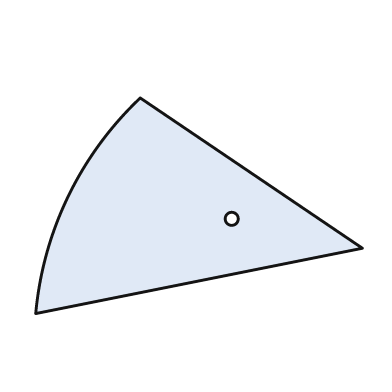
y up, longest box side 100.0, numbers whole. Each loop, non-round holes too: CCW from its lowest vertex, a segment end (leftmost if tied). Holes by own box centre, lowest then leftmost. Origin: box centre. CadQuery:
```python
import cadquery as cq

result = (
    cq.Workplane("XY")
    .moveTo(-50.0, -33.0)
    .lineTo(50.0, -13.0)
    .lineTo(-18.0, 33.0)
    .threePointArc((-40.0, 3.0), (-50.0, -33.0))
    .close()
    .moveTo(10.0, -4.0)
    .circle(2.0)
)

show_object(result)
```